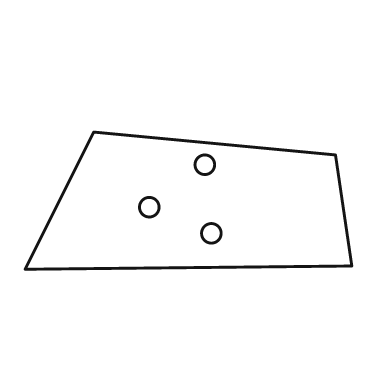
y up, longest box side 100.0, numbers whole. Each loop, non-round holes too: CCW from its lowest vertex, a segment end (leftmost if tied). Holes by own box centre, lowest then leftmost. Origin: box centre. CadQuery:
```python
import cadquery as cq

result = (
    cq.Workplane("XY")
    .moveTo(-50.0, -21.0)
    .lineTo(50.0, -20.0)
    .lineTo(45.0, 14.0)
    .lineTo(-29.0, 21.0)
    .close()
    .moveTo(7.0, -10.0)
    .circle(3.0)
    .moveTo(-12.0, -2.0)
    .circle(3.0)
    .moveTo(5.0, 11.0)
    .circle(3.0)
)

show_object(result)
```